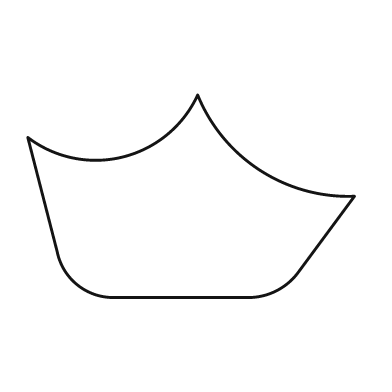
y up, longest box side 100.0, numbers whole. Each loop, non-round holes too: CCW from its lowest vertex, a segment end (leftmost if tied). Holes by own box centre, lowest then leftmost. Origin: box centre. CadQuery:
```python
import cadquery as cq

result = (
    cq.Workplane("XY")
    .moveTo(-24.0, -31.0)
    .lineTo(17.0, -31.0)
    .threePointArc((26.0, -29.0), (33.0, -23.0))
    .lineTo(50.0, 0.0)
    .threePointArc((21.0, 8.0), (2.0, 31.0))
    .threePointArc((-21.0, 12.0), (-50.0, 18.0))
    .lineTo(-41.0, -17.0)
    .threePointArc((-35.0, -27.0), (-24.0, -31.0))
    .close()
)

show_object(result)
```